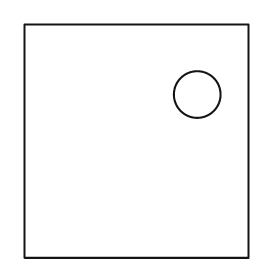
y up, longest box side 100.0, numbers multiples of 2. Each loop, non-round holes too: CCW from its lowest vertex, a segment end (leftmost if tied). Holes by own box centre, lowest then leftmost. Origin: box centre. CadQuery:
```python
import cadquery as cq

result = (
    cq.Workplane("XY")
    .moveTo(-48.0, -50.0)
    .lineTo(48.0, -50.0)
    .lineTo(48.0, 50.0)
    .lineTo(-48.0, 50.0)
    .close()
    .moveTo(26.0, 20.0)
    .circle(10.0)
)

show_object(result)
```